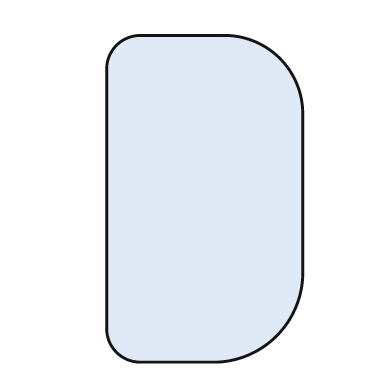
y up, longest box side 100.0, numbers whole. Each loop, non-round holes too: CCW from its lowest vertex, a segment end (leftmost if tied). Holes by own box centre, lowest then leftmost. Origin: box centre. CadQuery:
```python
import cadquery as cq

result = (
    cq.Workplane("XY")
    .moveTo(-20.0, -50.0)
    .lineTo(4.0, -50.0)
    .threePointArc((22.0, -42.0), (30.0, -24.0))
    .lineTo(30.0, 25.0)
    .threePointArc((23.0, 43.0), (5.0, 50.0))
    .lineTo(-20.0, 50.0)
    .threePointArc((-27.0, 47.0), (-30.0, 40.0))
    .lineTo(-30.0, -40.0)
    .threePointArc((-27.0, -47.0), (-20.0, -50.0))
    .close()
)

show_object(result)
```